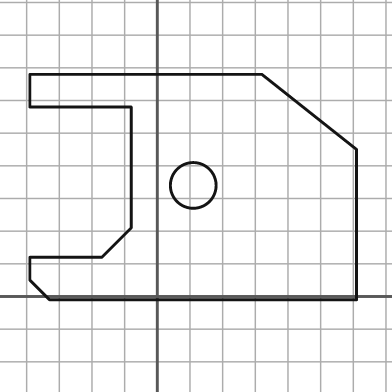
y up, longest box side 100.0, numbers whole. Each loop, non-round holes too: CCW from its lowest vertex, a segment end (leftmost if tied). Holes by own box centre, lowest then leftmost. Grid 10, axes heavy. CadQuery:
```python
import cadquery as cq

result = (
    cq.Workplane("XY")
    .moveTo(-33.0, -1.0)
    .lineTo(61.0, -1.0)
    .lineTo(61.0, 45.0)
    .lineTo(32.0, 68.0)
    .lineTo(-39.0, 68.0)
    .lineTo(-39.0, 58.0)
    .lineTo(-8.0, 58.0)
    .lineTo(-8.0, 21.0)
    .lineTo(-17.0, 12.0)
    .lineTo(-39.0, 12.0)
    .lineTo(-39.0, 5.0)
    .close()
    .moveTo(11.0, 34.0)
    .circle(7.0)
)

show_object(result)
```